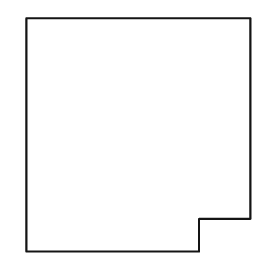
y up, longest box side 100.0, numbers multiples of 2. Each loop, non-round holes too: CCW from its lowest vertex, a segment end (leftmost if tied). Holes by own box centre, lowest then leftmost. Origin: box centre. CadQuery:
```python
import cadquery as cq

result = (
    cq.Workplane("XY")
    .moveTo(-48.0, -50.0)
    .lineTo(26.0, -50.0)
    .lineTo(26.0, -36.0)
    .lineTo(48.0, -36.0)
    .lineTo(48.0, 50.0)
    .lineTo(-48.0, 50.0)
    .close()
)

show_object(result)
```